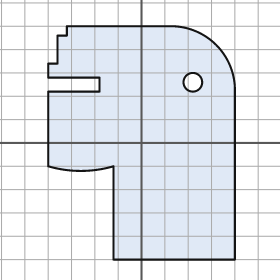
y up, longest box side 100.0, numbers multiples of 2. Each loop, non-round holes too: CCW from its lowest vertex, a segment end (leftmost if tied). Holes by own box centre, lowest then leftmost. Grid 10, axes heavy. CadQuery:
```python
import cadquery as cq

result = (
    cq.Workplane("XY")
    .moveTo(-12.0, -50.0)
    .lineTo(40.0, -50.0)
    .lineTo(40.0, 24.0)
    .threePointArc((32.0, 42.0), (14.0, 50.0))
    .lineTo(-32.0, 50.0)
    .lineTo(-32.0, 46.0)
    .lineTo(-36.0, 46.0)
    .lineTo(-36.0, 34.0)
    .lineTo(-40.0, 34.0)
    .lineTo(-40.0, 28.0)
    .lineTo(-18.0, 28.0)
    .lineTo(-18.0, 22.0)
    .lineTo(-40.0, 22.0)
    .lineTo(-40.0, -10.0)
    .threePointArc((-26.0, -12.0), (-12.0, -10.0))
    .close()
    .moveTo(22.0, 26.0)
    .circle(4.0)
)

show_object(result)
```